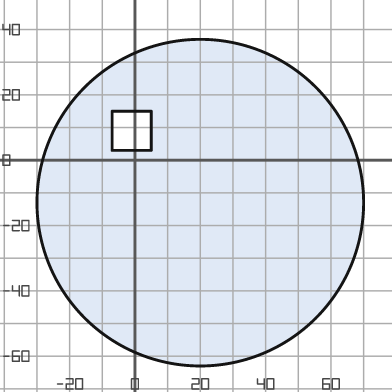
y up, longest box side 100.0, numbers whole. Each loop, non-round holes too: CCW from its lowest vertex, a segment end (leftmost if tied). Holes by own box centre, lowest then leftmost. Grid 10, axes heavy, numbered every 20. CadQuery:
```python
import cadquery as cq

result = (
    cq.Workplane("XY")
    .moveTo(20.0, -13.0)
    .circle(50.0)
    .moveTo(-7.0, 3.0)
    .lineTo(5.0, 3.0)
    .lineTo(5.0, 15.0)
    .lineTo(-7.0, 15.0)
    .close()
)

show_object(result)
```